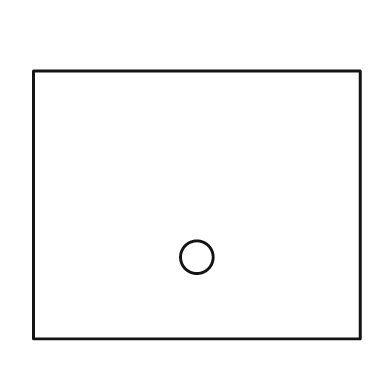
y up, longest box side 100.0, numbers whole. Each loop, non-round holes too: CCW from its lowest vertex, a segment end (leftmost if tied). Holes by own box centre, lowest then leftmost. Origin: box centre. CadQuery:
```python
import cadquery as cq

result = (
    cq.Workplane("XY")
    .moveTo(-50.0, -41.0)
    .lineTo(50.0, -41.0)
    .lineTo(50.0, 41.0)
    .lineTo(-50.0, 41.0)
    .close()
    .moveTo(0.0, -16.0)
    .circle(5.0)
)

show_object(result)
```